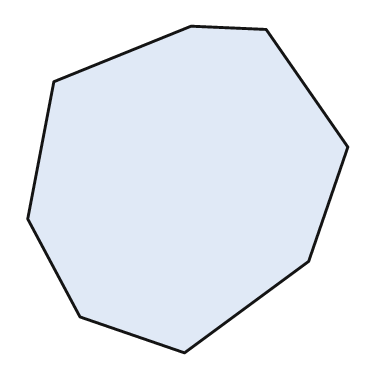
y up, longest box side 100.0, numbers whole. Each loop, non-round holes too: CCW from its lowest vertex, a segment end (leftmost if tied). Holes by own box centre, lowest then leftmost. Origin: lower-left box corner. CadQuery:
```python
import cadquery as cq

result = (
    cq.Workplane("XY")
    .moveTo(48.0, 0.0)
    .lineTo(86.0, 28.0)
    .lineTo(98.0, 63.0)
    .lineTo(73.0, 99.0)
    .lineTo(50.0, 100.0)
    .lineTo(8.0, 83.0)
    .lineTo(0.0, 41.0)
    .lineTo(16.0, 11.0)
    .close()
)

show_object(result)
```